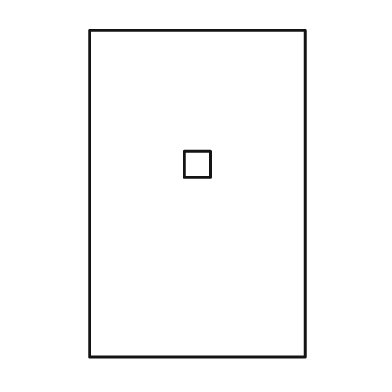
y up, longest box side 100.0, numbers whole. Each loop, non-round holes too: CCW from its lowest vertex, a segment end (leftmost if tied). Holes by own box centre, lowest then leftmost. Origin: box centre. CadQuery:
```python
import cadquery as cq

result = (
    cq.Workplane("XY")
    .moveTo(-33.0, -50.0)
    .lineTo(33.0, -50.0)
    .lineTo(33.0, 50.0)
    .lineTo(-33.0, 50.0)
    .close()
    .moveTo(-4.0, 5.0)
    .lineTo(4.0, 5.0)
    .lineTo(4.0, 13.0)
    .lineTo(-4.0, 13.0)
    .close()
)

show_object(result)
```